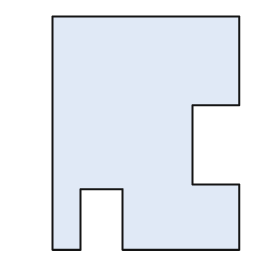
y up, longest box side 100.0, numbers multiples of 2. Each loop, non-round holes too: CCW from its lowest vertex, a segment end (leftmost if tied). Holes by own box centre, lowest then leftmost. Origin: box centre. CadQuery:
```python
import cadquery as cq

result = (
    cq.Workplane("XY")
    .moveTo(-40.0, -50.0)
    .lineTo(-28.0, -50.0)
    .lineTo(-28.0, -24.0)
    .lineTo(-10.0, -24.0)
    .lineTo(-10.0, -50.0)
    .lineTo(40.0, -50.0)
    .lineTo(40.0, -22.0)
    .lineTo(20.0, -22.0)
    .lineTo(20.0, 12.0)
    .lineTo(40.0, 12.0)
    .lineTo(40.0, 50.0)
    .lineTo(-40.0, 50.0)
    .close()
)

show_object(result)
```